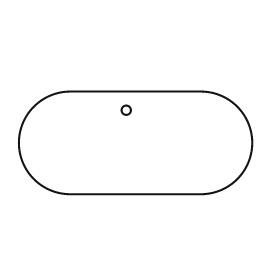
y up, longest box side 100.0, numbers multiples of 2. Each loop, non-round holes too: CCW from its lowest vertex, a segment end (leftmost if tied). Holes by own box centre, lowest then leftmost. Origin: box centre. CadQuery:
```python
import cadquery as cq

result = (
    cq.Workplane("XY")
    .moveTo(-28.0, -22.0)
    .lineTo(28.0, -22.0)
    .threePointArc((50.0, 0.0), (28.0, 22.0))
    .lineTo(-28.0, 22.0)
    .threePointArc((-50.0, 0.0), (-28.0, -22.0))
    .close()
    .moveTo(-4.0, 14.0)
    .circle(2.0)
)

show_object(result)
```